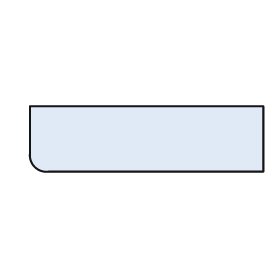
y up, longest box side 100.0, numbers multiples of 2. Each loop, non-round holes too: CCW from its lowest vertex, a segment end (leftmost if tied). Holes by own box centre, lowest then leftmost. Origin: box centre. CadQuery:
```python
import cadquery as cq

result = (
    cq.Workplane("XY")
    .moveTo(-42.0, -14.0)
    .lineTo(50.0, -14.0)
    .lineTo(50.0, 14.0)
    .lineTo(-50.0, 14.0)
    .lineTo(-50.0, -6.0)
    .threePointArc((-48.0, -12.0), (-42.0, -14.0))
    .close()
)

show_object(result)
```